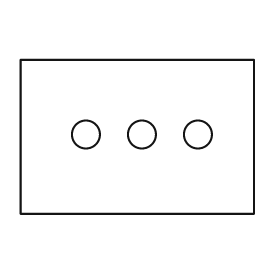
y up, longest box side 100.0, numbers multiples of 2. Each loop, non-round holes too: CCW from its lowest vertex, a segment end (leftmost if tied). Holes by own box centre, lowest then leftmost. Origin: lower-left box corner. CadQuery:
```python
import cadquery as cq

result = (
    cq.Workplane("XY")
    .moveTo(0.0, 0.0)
    .lineTo(100.0, 0.0)
    .lineTo(100.0, 66.0)
    .lineTo(0.0, 66.0)
    .close()
    .moveTo(28.0, 34.0)
    .circle(6.0)
    .moveTo(52.0, 34.0)
    .circle(6.0)
    .moveTo(76.0, 34.0)
    .circle(6.0)
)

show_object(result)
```